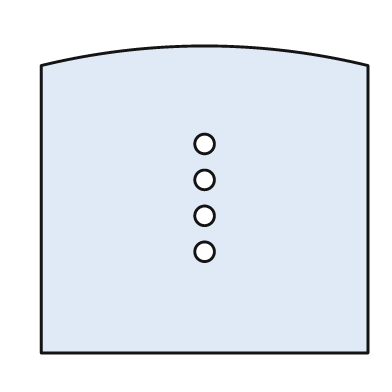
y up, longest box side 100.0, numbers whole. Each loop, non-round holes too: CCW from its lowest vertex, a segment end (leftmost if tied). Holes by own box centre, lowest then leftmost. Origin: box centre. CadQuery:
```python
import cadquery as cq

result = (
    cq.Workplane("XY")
    .moveTo(-50.0, -47.0)
    .lineTo(50.0, -47.0)
    .lineTo(50.0, 41.0)
    .threePointArc((0.0, 47.0), (-50.0, 41.0))
    .close()
    .moveTo(0.0, -16.0)
    .circle(3.0)
    .moveTo(0.0, -5.0)
    .circle(3.0)
    .moveTo(0.0, 6.0)
    .circle(3.0)
    .moveTo(0.0, 17.0)
    .circle(3.0)
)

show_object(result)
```